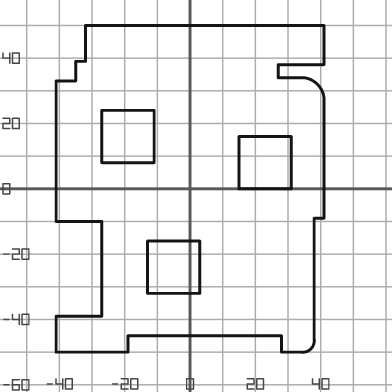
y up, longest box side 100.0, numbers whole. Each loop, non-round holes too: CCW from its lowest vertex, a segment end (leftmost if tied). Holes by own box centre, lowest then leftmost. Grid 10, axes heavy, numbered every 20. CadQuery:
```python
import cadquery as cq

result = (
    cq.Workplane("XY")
    .moveTo(-41.0, -50.0)
    .lineTo(-19.0, -50.0)
    .lineTo(-19.0, -45.0)
    .lineTo(28.0, -45.0)
    .lineTo(28.0, -50.0)
    .lineTo(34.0, -50.0)
    .threePointArc((37.0, -49.0), (38.0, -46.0))
    .lineTo(38.0, -9.0)
    .lineTo(41.0, -9.0)
    .lineTo(41.0, 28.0)
    .threePointArc((39.0, 32.0), (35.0, 34.0))
    .lineTo(27.0, 34.0)
    .lineTo(27.0, 38.0)
    .lineTo(41.0, 38.0)
    .lineTo(41.0, 50.0)
    .lineTo(-32.0, 50.0)
    .lineTo(-32.0, 39.0)
    .lineTo(-35.0, 39.0)
    .lineTo(-35.0, 33.0)
    .lineTo(-41.0, 33.0)
    .lineTo(-41.0, -10.0)
    .lineTo(-27.0, -10.0)
    .lineTo(-27.0, -39.0)
    .lineTo(-41.0, -39.0)
    .close()
    .moveTo(-13.0, -32.0)
    .lineTo(3.0, -32.0)
    .lineTo(3.0, -16.0)
    .lineTo(-13.0, -16.0)
    .close()
    .moveTo(15.0, 0.0)
    .lineTo(31.0, 0.0)
    .lineTo(31.0, 16.0)
    .lineTo(15.0, 16.0)
    .close()
    .moveTo(-27.0, 8.0)
    .lineTo(-11.0, 8.0)
    .lineTo(-11.0, 24.0)
    .lineTo(-27.0, 24.0)
    .close()
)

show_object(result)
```